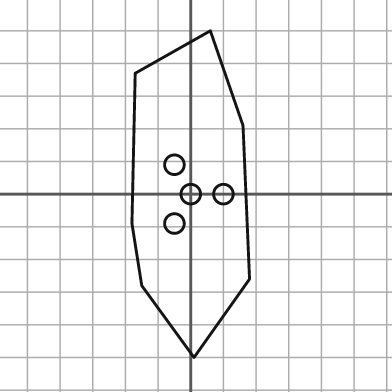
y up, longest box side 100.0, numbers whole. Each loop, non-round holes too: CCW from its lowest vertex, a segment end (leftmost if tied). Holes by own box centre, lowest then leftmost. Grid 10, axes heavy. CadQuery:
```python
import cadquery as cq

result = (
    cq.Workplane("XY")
    .moveTo(1.0, -50.0)
    .lineTo(18.0, -26.0)
    .lineTo(16.0, 21.0)
    .lineTo(6.0, 50.0)
    .lineTo(-17.0, 37.0)
    .lineTo(-18.0, -9.0)
    .lineTo(-15.0, -28.0)
    .close()
    .moveTo(-5.0, -9.0)
    .circle(3.0)
    .moveTo(0.0, 0.0)
    .circle(3.0)
    .moveTo(10.0, 0.0)
    .circle(3.0)
    .moveTo(-5.0, 9.0)
    .circle(3.0)
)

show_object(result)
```